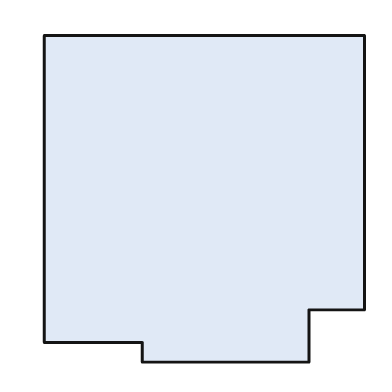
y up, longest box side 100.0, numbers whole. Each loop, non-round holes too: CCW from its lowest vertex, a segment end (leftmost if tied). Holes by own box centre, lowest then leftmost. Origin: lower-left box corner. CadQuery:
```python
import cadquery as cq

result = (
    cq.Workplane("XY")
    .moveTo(30.0, 0.0)
    .lineTo(81.0, 0.0)
    .lineTo(81.0, 16.0)
    .lineTo(98.0, 16.0)
    .lineTo(98.0, 100.0)
    .lineTo(0.0, 100.0)
    .lineTo(0.0, 6.0)
    .lineTo(30.0, 6.0)
    .close()
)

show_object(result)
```